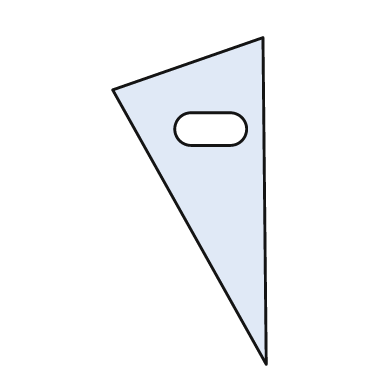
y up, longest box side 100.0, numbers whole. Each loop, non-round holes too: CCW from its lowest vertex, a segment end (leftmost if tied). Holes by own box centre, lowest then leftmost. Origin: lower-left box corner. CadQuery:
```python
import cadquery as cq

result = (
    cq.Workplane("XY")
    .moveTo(47.0, 0.0)
    .lineTo(46.0, 100.0)
    .lineTo(0.0, 84.0)
    .close()
    .moveTo(24.0, 67.0)
    .lineTo(36.0, 67.0)
    .threePointArc((41.0, 72.0), (36.0, 77.0))
    .lineTo(24.0, 77.0)
    .threePointArc((19.0, 72.0), (24.0, 67.0))
    .close()
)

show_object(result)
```